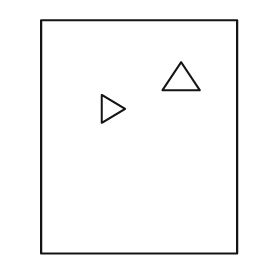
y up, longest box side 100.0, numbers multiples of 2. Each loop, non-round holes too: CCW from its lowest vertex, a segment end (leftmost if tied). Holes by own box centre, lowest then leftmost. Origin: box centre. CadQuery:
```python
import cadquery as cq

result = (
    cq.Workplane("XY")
    .moveTo(-42.0, -50.0)
    .lineTo(42.0, -50.0)
    .lineTo(42.0, 50.0)
    .lineTo(-42.0, 50.0)
    .close()
    .moveTo(-16.0, 6.0)
    .lineTo(-6.0, 12.0)
    .lineTo(-16.0, 18.0)
    .close()
    .moveTo(10.0, 20.0)
    .lineTo(26.0, 20.0)
    .lineTo(18.0, 32.0)
    .close()
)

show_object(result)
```